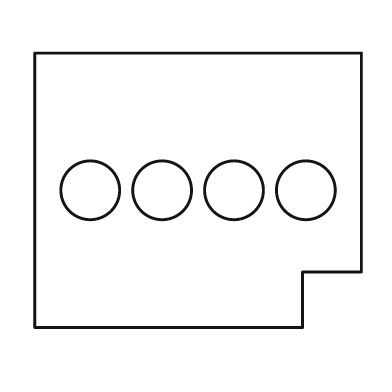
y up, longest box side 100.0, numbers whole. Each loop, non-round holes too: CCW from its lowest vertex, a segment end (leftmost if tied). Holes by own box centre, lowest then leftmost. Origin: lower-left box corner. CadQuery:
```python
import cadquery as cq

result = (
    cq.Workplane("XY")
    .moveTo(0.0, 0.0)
    .lineTo(82.0, 0.0)
    .lineTo(82.0, 17.0)
    .lineTo(100.0, 17.0)
    .lineTo(100.0, 84.0)
    .lineTo(0.0, 84.0)
    .close()
    .moveTo(17.0, 42.0)
    .circle(9.0)
    .moveTo(39.0, 42.0)
    .circle(9.0)
    .moveTo(61.0, 42.0)
    .circle(9.0)
    .moveTo(83.0, 42.0)
    .circle(9.0)
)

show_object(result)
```